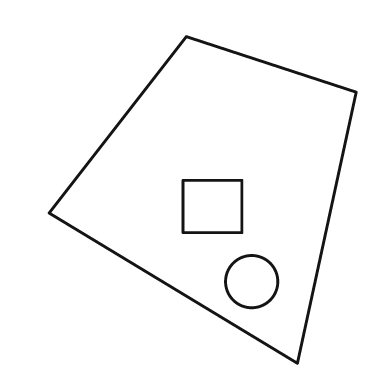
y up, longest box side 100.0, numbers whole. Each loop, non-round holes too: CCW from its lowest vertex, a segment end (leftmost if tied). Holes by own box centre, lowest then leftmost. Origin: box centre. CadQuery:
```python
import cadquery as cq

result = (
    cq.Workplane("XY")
    .moveTo(29.0, -50.0)
    .lineTo(47.0, 33.0)
    .lineTo(-5.0, 50.0)
    .lineTo(-47.0, -4.0)
    .close()
    .moveTo(15.0, -25.0)
    .circle(8.0)
    .moveTo(-6.0, -10.0)
    .lineTo(12.0, -10.0)
    .lineTo(12.0, 6.0)
    .lineTo(-6.0, 6.0)
    .close()
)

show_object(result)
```